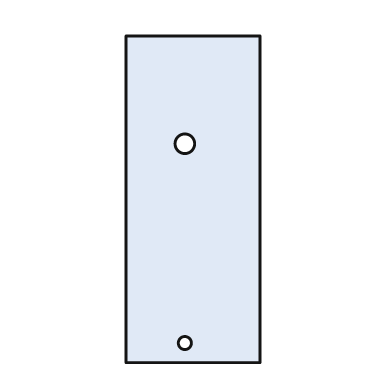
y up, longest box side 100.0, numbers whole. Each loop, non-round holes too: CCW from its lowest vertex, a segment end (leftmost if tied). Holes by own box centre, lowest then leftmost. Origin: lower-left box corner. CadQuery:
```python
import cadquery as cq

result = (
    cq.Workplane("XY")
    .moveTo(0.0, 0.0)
    .lineTo(41.0, 0.0)
    .lineTo(41.0, 100.0)
    .lineTo(0.0, 100.0)
    .close()
    .moveTo(18.0, 6.0)
    .circle(2.0)
    .moveTo(18.0, 67.0)
    .circle(3.0)
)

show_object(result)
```